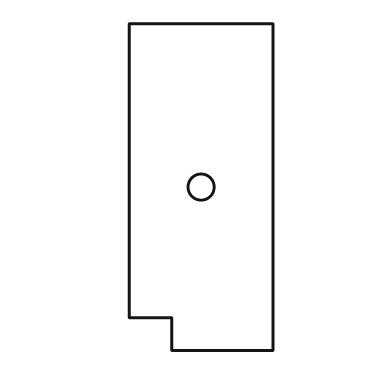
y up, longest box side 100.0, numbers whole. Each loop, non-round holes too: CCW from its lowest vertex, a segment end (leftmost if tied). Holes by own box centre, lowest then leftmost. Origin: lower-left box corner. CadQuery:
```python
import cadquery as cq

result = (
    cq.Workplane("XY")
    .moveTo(13.0, 0.0)
    .lineTo(44.0, 0.0)
    .lineTo(44.0, 100.0)
    .lineTo(0.0, 100.0)
    .lineTo(0.0, 10.0)
    .lineTo(13.0, 10.0)
    .close()
    .moveTo(22.0, 50.0)
    .circle(4.0)
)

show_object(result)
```